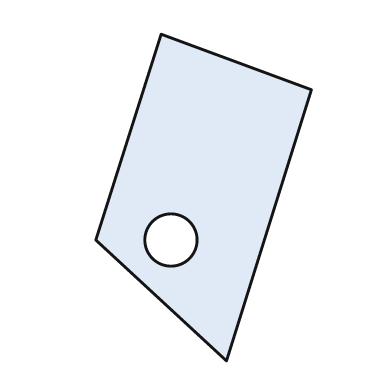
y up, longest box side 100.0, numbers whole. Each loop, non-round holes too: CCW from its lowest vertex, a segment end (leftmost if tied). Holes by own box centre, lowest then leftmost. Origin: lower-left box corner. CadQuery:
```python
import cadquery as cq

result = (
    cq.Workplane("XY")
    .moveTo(40.0, 0.0)
    .lineTo(66.0, 83.0)
    .lineTo(20.0, 100.0)
    .lineTo(0.0, 37.0)
    .close()
    .moveTo(23.0, 37.0)
    .circle(8.0)
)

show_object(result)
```